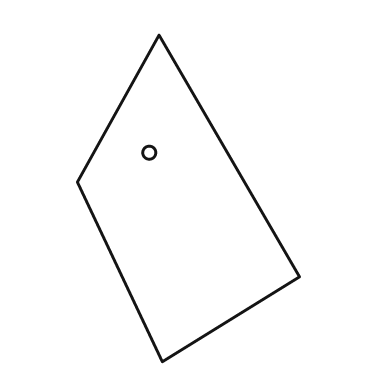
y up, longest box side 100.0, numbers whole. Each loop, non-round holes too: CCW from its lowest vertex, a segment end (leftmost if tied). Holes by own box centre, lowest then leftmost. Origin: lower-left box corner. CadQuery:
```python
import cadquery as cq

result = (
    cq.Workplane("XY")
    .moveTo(26.0, 0.0)
    .lineTo(68.0, 26.0)
    .lineTo(25.0, 100.0)
    .lineTo(0.0, 55.0)
    .close()
    .moveTo(22.0, 64.0)
    .circle(2.0)
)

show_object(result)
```